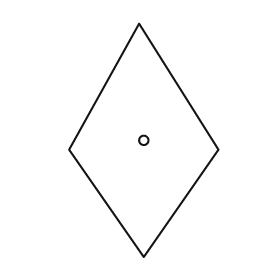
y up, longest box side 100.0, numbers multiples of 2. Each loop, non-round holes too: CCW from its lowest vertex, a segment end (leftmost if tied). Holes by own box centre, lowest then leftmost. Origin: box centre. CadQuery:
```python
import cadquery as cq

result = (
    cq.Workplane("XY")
    .moveTo(0.0, -50.0)
    .lineTo(32.0, -4.0)
    .lineTo(-2.0, 50.0)
    .lineTo(-32.0, -4.0)
    .close()
    .moveTo(0.0, 0.0)
    .circle(2.0)
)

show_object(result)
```